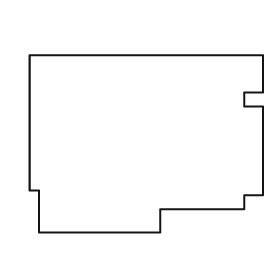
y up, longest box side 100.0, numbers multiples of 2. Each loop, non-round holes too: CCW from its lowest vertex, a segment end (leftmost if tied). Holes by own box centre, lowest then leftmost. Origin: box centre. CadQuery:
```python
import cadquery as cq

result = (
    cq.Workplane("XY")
    .moveTo(-46.0, -38.0)
    .lineTo(6.0, -38.0)
    .lineTo(6.0, -28.0)
    .lineTo(42.0, -28.0)
    .lineTo(42.0, -22.0)
    .lineTo(50.0, -22.0)
    .lineTo(50.0, 16.0)
    .lineTo(42.0, 16.0)
    .lineTo(42.0, 22.0)
    .lineTo(50.0, 22.0)
    .lineTo(50.0, 38.0)
    .lineTo(-50.0, 38.0)
    .lineTo(-50.0, -20.0)
    .lineTo(-46.0, -20.0)
    .close()
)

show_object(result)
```